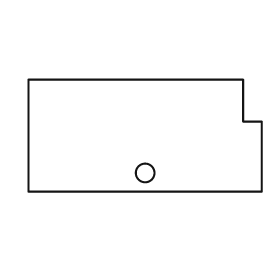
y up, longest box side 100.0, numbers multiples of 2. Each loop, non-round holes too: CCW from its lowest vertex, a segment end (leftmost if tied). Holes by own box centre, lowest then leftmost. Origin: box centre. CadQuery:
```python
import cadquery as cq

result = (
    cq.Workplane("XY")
    .moveTo(-50.0, -24.0)
    .lineTo(50.0, -24.0)
    .lineTo(50.0, 6.0)
    .lineTo(42.0, 6.0)
    .lineTo(42.0, 24.0)
    .lineTo(-50.0, 24.0)
    .close()
    .moveTo(0.0, -16.0)
    .circle(4.0)
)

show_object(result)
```